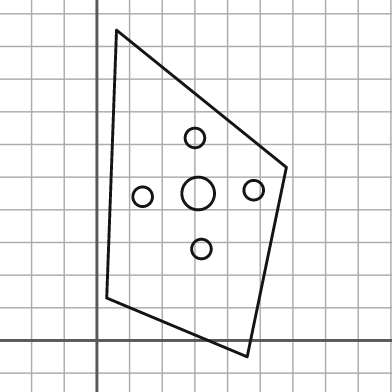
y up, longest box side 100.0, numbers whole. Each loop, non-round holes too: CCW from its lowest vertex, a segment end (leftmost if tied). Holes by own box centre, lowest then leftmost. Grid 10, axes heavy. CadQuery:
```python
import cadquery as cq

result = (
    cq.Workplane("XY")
    .moveTo(46.0, -5.0)
    .lineTo(58.0, 53.0)
    .lineTo(6.0, 95.0)
    .lineTo(3.0, 13.0)
    .close()
    .moveTo(32.0, 28.0)
    .circle(3.0)
    .moveTo(14.0, 44.0)
    .circle(3.0)
    .moveTo(31.0, 45.0)
    .circle(5.0)
    .moveTo(48.0, 46.0)
    .circle(3.0)
    .moveTo(30.0, 62.0)
    .circle(3.0)
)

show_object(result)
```